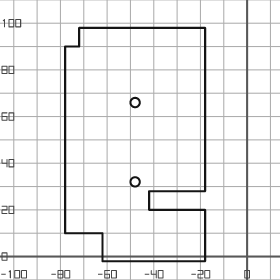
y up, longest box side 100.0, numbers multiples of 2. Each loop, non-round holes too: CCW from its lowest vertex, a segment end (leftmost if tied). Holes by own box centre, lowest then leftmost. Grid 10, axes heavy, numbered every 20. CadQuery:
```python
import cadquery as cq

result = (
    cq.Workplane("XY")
    .moveTo(-62.0, -2.0)
    .lineTo(-18.0, -2.0)
    .lineTo(-18.0, 20.0)
    .lineTo(-42.0, 20.0)
    .lineTo(-42.0, 28.0)
    .lineTo(-18.0, 28.0)
    .lineTo(-18.0, 98.0)
    .lineTo(-72.0, 98.0)
    .lineTo(-72.0, 90.0)
    .lineTo(-78.0, 90.0)
    .lineTo(-78.0, 10.0)
    .lineTo(-62.0, 10.0)
    .close()
    .moveTo(-48.0, 32.0)
    .circle(2.0)
    .moveTo(-48.0, 66.0)
    .circle(2.0)
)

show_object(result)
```